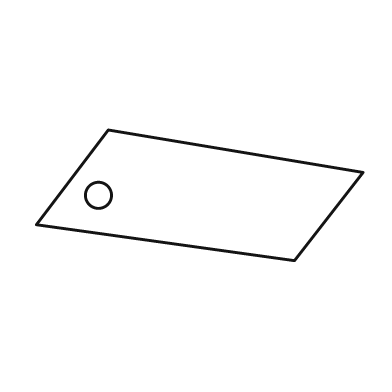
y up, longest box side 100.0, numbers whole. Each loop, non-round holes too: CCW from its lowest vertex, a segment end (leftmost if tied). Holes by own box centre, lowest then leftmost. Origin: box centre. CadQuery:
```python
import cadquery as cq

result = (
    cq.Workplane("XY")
    .moveTo(29.0, -20.0)
    .lineTo(50.0, 7.0)
    .lineTo(-28.0, 20.0)
    .lineTo(-50.0, -9.0)
    .close()
    .moveTo(-31.0, 0.0)
    .circle(4.0)
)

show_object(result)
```